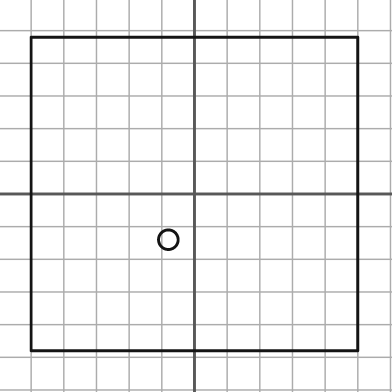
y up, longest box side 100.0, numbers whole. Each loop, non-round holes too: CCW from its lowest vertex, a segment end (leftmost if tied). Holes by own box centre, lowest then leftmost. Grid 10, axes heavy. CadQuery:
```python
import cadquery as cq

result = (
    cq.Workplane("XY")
    .moveTo(-50.0, -48.0)
    .lineTo(50.0, -48.0)
    .lineTo(50.0, 48.0)
    .lineTo(-50.0, 48.0)
    .close()
    .moveTo(-8.0, -14.0)
    .circle(3.0)
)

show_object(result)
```